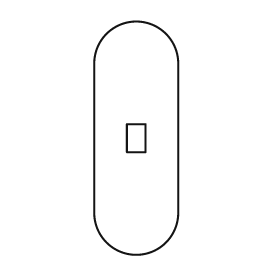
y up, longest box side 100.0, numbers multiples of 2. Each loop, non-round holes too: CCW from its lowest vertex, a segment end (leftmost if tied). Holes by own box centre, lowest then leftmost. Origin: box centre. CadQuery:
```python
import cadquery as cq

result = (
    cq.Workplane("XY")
    .moveTo(-18.0, -32.0)
    .threePointArc((0.0, -50.0), (18.0, -32.0))
    .lineTo(18.0, 32.0)
    .threePointArc((0.0, 50.0), (-18.0, 32.0))
    .close()
    .moveTo(-4.0, -6.0)
    .lineTo(4.0, -6.0)
    .lineTo(4.0, 6.0)
    .lineTo(-4.0, 6.0)
    .close()
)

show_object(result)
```